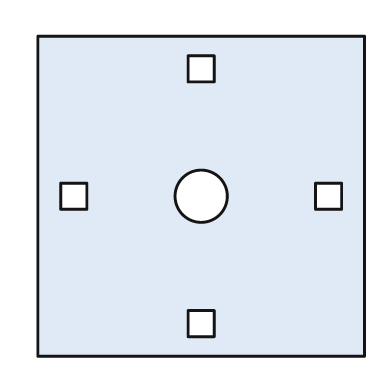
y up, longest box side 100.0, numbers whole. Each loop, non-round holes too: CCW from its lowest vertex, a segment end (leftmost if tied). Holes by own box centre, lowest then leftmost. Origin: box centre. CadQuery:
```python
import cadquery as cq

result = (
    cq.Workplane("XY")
    .moveTo(-50.0, -49.0)
    .lineTo(50.0, -49.0)
    .lineTo(50.0, 49.0)
    .lineTo(-50.0, 49.0)
    .close()
    .moveTo(-4.0, -43.0)
    .lineTo(4.0, -43.0)
    .lineTo(4.0, -35.0)
    .lineTo(-4.0, -35.0)
    .close()
    .moveTo(-43.0, -4.0)
    .lineTo(-35.0, -4.0)
    .lineTo(-35.0, 4.0)
    .lineTo(-43.0, 4.0)
    .close()
    .moveTo(0.0, 0.0)
    .circle(8.0)
    .moveTo(35.0, -4.0)
    .lineTo(43.0, -4.0)
    .lineTo(43.0, 4.0)
    .lineTo(35.0, 4.0)
    .close()
    .moveTo(-4.0, 35.0)
    .lineTo(4.0, 35.0)
    .lineTo(4.0, 43.0)
    .lineTo(-4.0, 43.0)
    .close()
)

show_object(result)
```